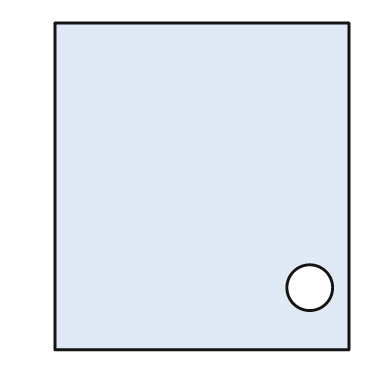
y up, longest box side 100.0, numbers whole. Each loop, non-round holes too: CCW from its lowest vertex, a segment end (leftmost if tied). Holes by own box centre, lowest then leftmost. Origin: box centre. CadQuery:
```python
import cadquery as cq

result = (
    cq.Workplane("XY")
    .moveTo(-45.0, -50.0)
    .lineTo(45.0, -50.0)
    .lineTo(45.0, 50.0)
    .lineTo(-45.0, 50.0)
    .close()
    .moveTo(33.0, -31.0)
    .circle(7.0)
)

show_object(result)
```